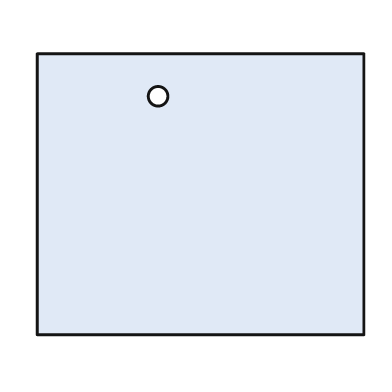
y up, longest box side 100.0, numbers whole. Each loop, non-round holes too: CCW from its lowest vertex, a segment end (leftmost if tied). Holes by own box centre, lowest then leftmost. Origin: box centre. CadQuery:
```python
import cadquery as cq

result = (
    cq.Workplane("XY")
    .moveTo(-50.0, -43.0)
    .lineTo(50.0, -43.0)
    .lineTo(50.0, 43.0)
    .lineTo(-50.0, 43.0)
    .close()
    .moveTo(-13.0, 30.0)
    .circle(3.0)
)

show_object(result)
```